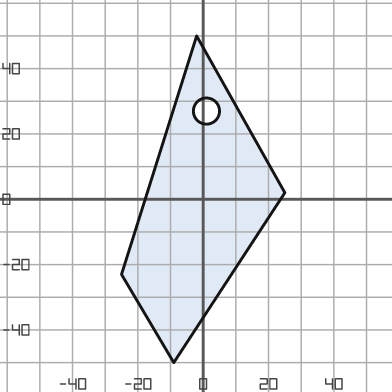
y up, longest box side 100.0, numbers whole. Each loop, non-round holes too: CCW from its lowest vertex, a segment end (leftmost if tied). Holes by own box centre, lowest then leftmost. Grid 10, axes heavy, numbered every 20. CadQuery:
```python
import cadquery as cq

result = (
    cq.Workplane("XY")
    .moveTo(-9.0, -50.0)
    .lineTo(25.0, 2.0)
    .lineTo(-2.0, 50.0)
    .lineTo(-25.0, -23.0)
    .close()
    .moveTo(1.0, 27.0)
    .circle(4.0)
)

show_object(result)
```